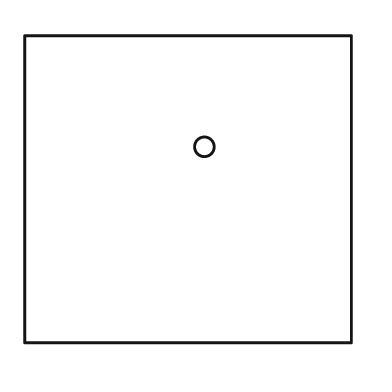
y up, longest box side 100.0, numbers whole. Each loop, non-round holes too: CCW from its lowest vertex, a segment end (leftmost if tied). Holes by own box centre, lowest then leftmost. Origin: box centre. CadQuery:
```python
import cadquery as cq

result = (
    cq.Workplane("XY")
    .moveTo(-50.0, -47.0)
    .lineTo(50.0, -47.0)
    .lineTo(50.0, 47.0)
    .lineTo(-50.0, 47.0)
    .close()
    .moveTo(5.0, 13.0)
    .circle(3.0)
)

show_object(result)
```